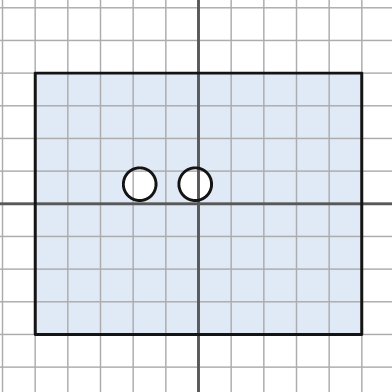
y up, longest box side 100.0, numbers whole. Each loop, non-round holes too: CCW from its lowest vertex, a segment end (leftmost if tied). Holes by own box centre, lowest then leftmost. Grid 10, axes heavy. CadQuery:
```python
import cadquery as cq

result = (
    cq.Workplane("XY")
    .moveTo(-50.0, -40.0)
    .lineTo(50.0, -40.0)
    .lineTo(50.0, 40.0)
    .lineTo(-50.0, 40.0)
    .close()
    .moveTo(-18.0, 6.0)
    .circle(5.0)
    .moveTo(-1.0, 6.0)
    .circle(5.0)
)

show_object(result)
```